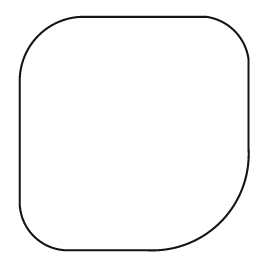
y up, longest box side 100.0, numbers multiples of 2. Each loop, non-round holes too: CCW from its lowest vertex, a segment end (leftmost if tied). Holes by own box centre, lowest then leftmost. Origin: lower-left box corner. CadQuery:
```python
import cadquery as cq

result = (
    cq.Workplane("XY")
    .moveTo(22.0, 0.0)
    .lineTo(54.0, 0.0)
    .threePointArc((86.0, 12.0), (98.0, 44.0))
    .lineTo(98.0, 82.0)
    .threePointArc((92.0, 94.0), (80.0, 100.0))
    .lineTo(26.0, 100.0)
    .threePointArc((8.0, 92.0), (0.0, 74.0))
    .lineTo(0.0, 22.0)
    .threePointArc((6.0, 6.0), (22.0, 0.0))
    .close()
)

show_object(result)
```